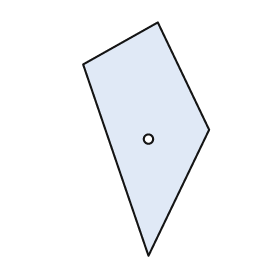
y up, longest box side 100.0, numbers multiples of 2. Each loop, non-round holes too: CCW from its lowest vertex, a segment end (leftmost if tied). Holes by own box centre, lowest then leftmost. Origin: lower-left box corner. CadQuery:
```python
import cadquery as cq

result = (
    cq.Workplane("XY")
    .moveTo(28.0, 0.0)
    .lineTo(54.0, 54.0)
    .lineTo(32.0, 100.0)
    .lineTo(0.0, 82.0)
    .close()
    .moveTo(28.0, 50.0)
    .circle(2.0)
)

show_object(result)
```